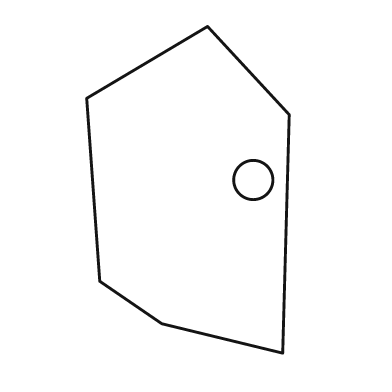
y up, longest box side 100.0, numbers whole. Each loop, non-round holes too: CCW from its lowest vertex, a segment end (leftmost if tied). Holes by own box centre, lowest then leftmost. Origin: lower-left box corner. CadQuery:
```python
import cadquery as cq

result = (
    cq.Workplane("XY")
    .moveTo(60.0, 0.0)
    .lineTo(62.0, 73.0)
    .lineTo(37.0, 100.0)
    .lineTo(0.0, 78.0)
    .lineTo(4.0, 22.0)
    .lineTo(23.0, 9.0)
    .close()
    .moveTo(51.0, 53.0)
    .circle(6.0)
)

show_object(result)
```